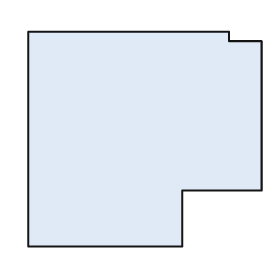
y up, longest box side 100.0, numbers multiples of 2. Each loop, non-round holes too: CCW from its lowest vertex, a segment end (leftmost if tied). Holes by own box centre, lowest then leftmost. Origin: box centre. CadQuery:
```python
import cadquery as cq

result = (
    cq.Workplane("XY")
    .moveTo(-50.0, -46.0)
    .lineTo(16.0, -46.0)
    .lineTo(16.0, -22.0)
    .lineTo(50.0, -22.0)
    .lineTo(50.0, 42.0)
    .lineTo(36.0, 42.0)
    .lineTo(36.0, 46.0)
    .lineTo(-50.0, 46.0)
    .close()
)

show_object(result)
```